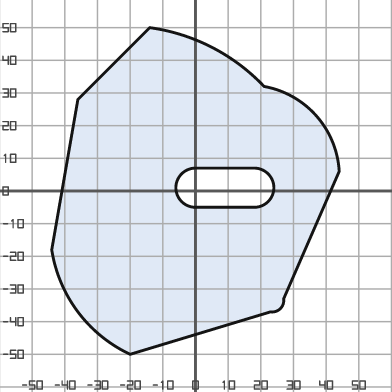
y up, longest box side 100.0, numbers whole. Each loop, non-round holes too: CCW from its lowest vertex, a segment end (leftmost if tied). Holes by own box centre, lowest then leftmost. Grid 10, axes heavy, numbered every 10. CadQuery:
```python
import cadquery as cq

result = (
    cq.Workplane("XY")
    .moveTo(-20.0, -50.0)
    .lineTo(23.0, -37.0)
    .threePointArc((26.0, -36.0), (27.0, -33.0))
    .lineTo(44.0, 6.0)
    .threePointArc((37.0, 23.0), (21.0, 32.0))
    .threePointArc((5.0, 44.0), (-14.0, 50.0))
    .lineTo(-36.0, 28.0)
    .lineTo(-44.0, -18.0)
    .threePointArc((-36.0, -37.0), (-20.0, -50.0))
    .close()
    .moveTo(0.0, -5.0)
    .lineTo(18.0, -5.0)
    .threePointArc((24.0, 1.0), (18.0, 7.0))
    .lineTo(0.0, 7.0)
    .threePointArc((-6.0, 1.0), (0.0, -5.0))
    .close()
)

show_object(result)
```